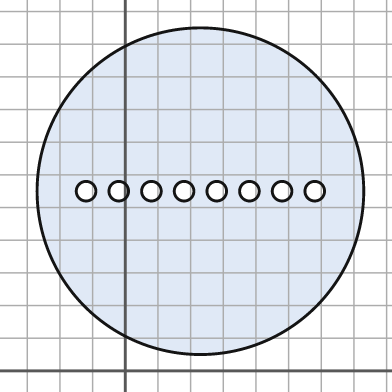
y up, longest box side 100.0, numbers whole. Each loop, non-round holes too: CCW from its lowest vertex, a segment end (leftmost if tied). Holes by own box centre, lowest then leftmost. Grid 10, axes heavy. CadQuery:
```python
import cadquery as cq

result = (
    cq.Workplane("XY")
    .moveTo(23.0, 55.0)
    .circle(50.0)
    .moveTo(-12.0, 55.0)
    .circle(3.0)
    .moveTo(-2.0, 55.0)
    .circle(3.0)
    .moveTo(8.0, 55.0)
    .circle(3.0)
    .moveTo(18.0, 55.0)
    .circle(3.0)
    .moveTo(28.0, 55.0)
    .circle(3.0)
    .moveTo(38.0, 55.0)
    .circle(3.0)
    .moveTo(48.0, 55.0)
    .circle(3.0)
    .moveTo(58.0, 55.0)
    .circle(3.0)
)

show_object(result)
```